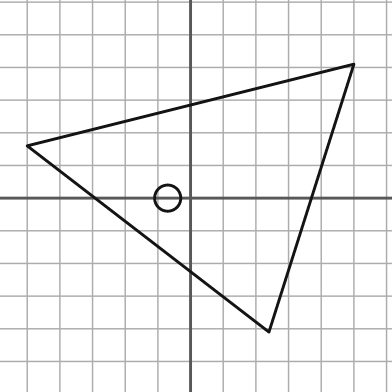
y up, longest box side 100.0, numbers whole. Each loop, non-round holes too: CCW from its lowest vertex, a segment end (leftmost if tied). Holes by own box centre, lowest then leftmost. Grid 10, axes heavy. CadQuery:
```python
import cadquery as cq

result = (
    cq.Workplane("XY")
    .moveTo(24.0, -41.0)
    .lineTo(50.0, 41.0)
    .lineTo(-50.0, 16.0)
    .close()
    .moveTo(-7.0, 0.0)
    .circle(4.0)
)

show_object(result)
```